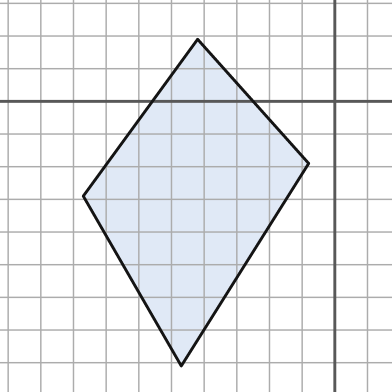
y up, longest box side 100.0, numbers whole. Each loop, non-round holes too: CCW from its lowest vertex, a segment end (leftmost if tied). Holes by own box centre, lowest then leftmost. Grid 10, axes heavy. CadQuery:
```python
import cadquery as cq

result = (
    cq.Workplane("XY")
    .moveTo(-47.0, -81.0)
    .lineTo(-8.0, -19.0)
    .lineTo(-42.0, 19.0)
    .lineTo(-77.0, -29.0)
    .close()
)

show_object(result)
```